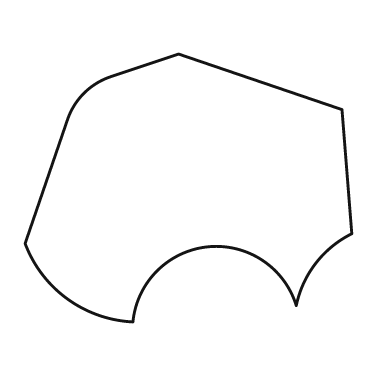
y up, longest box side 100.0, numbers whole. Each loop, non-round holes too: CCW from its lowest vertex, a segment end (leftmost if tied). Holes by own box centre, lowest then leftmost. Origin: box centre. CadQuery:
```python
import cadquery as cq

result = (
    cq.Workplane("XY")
    .moveTo(-17.0, -41.0)
    .threePointArc((6.0, -18.0), (33.0, -36.0))
    .threePointArc((39.0, -23.0), (50.0, -14.0))
    .lineTo(47.0, 24.0)
    .lineTo(-3.0, 41.0)
    .lineTo(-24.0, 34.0)
    .threePointArc((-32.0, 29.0), (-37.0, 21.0))
    .lineTo(-50.0, -17.0)
    .threePointArc((-37.0, -34.0), (-17.0, -41.0))
    .close()
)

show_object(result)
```